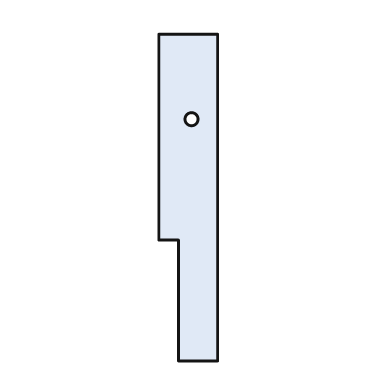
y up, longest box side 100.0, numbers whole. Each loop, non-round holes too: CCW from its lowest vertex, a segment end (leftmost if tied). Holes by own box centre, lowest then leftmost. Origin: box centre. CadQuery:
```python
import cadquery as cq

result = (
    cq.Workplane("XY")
    .moveTo(-3.0, -50.0)
    .lineTo(9.0, -50.0)
    .lineTo(9.0, 50.0)
    .lineTo(-9.0, 50.0)
    .lineTo(-9.0, -13.0)
    .lineTo(-3.0, -13.0)
    .close()
    .moveTo(1.0, 24.0)
    .circle(2.0)
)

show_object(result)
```